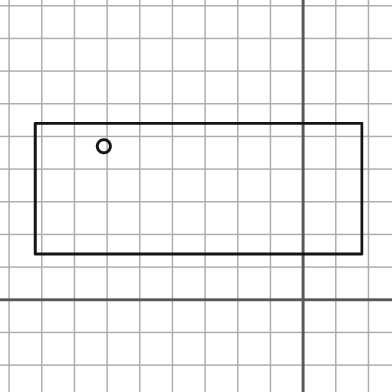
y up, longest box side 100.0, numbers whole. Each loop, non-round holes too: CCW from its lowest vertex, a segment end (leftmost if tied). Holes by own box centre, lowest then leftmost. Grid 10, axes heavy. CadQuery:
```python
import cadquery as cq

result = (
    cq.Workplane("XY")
    .moveTo(-82.0, 14.0)
    .lineTo(18.0, 14.0)
    .lineTo(18.0, 54.0)
    .lineTo(-82.0, 54.0)
    .close()
    .moveTo(-61.0, 47.0)
    .circle(2.0)
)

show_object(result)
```